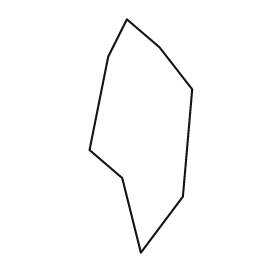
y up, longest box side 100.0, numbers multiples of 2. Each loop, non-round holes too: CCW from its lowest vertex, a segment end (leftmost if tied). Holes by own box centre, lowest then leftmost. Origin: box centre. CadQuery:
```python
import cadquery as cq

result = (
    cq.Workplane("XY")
    .moveTo(0.0, -50.0)
    .lineTo(18.0, -26.0)
    .lineTo(22.0, 20.0)
    .lineTo(8.0, 38.0)
    .lineTo(-6.0, 50.0)
    .lineTo(-14.0, 34.0)
    .lineTo(-22.0, -6.0)
    .lineTo(-8.0, -18.0)
    .close()
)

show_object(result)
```